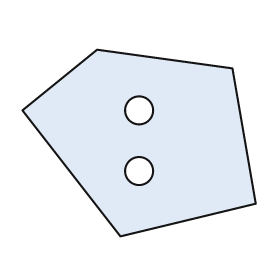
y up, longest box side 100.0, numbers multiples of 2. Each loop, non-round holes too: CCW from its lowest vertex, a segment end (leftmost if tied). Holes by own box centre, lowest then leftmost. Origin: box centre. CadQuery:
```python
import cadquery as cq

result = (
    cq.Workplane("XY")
    .moveTo(-8.0, -40.0)
    .lineTo(50.0, -26.0)
    .lineTo(40.0, 32.0)
    .lineTo(-18.0, 40.0)
    .lineTo(-50.0, 14.0)
    .close()
    .moveTo(0.0, -12.0)
    .circle(6.0)
    .moveTo(0.0, 14.0)
    .circle(6.0)
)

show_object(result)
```